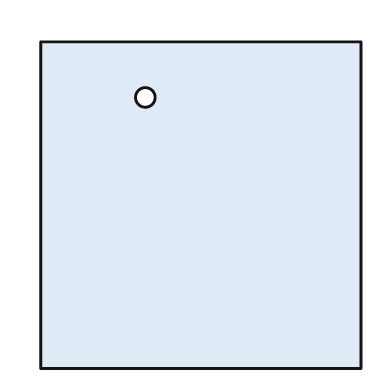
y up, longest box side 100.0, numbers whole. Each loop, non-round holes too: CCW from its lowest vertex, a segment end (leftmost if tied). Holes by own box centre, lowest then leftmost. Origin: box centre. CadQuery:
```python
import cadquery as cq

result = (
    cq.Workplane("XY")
    .moveTo(-49.0, -50.0)
    .lineTo(49.0, -50.0)
    .lineTo(49.0, 50.0)
    .lineTo(-49.0, 50.0)
    .close()
    .moveTo(-17.0, 33.0)
    .circle(3.0)
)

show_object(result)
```